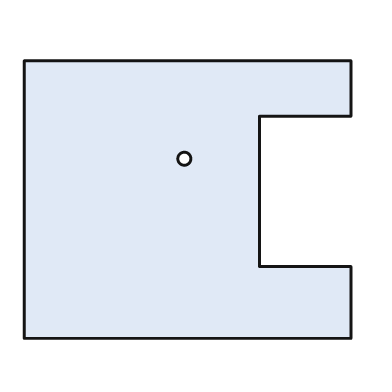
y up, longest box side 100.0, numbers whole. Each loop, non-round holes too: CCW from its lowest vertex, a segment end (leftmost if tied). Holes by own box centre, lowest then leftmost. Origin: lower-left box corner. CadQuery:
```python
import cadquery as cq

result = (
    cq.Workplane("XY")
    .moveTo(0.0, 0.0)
    .lineTo(100.0, 0.0)
    .lineTo(100.0, 22.0)
    .lineTo(72.0, 22.0)
    .lineTo(72.0, 68.0)
    .lineTo(100.0, 68.0)
    .lineTo(100.0, 85.0)
    .lineTo(0.0, 85.0)
    .close()
    .moveTo(49.0, 55.0)
    .circle(2.0)
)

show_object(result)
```